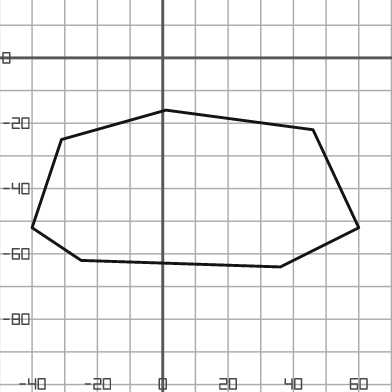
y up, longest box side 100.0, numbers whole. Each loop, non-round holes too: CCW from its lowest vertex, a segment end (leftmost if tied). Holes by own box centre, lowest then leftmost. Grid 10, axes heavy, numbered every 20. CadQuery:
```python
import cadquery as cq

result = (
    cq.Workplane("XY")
    .moveTo(36.0, -64.0)
    .lineTo(60.0, -52.0)
    .lineTo(46.0, -22.0)
    .lineTo(1.0, -16.0)
    .lineTo(-31.0, -25.0)
    .lineTo(-40.0, -52.0)
    .lineTo(-25.0, -62.0)
    .close()
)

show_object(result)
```